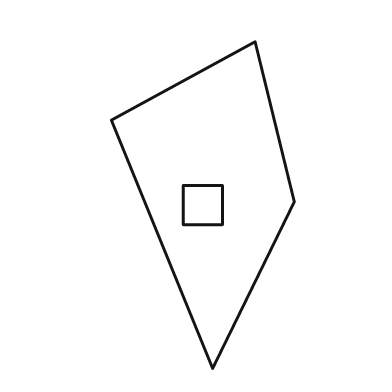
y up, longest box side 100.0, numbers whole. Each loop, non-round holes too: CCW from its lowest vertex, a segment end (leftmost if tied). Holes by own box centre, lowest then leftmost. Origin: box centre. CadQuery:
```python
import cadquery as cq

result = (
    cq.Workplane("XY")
    .moveTo(3.0, -50.0)
    .lineTo(28.0, 1.0)
    .lineTo(16.0, 50.0)
    .lineTo(-28.0, 26.0)
    .close()
    .moveTo(-6.0, -6.0)
    .lineTo(6.0, -6.0)
    .lineTo(6.0, 6.0)
    .lineTo(-6.0, 6.0)
    .close()
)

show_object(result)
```